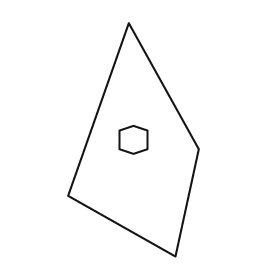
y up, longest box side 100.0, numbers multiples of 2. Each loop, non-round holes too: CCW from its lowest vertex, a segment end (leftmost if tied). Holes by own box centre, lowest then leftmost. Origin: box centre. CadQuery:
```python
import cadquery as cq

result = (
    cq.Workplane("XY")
    .moveTo(18.0, -50.0)
    .lineTo(28.0, -4.0)
    .lineTo(-2.0, 50.0)
    .lineTo(-28.0, -24.0)
    .close()
    .moveTo(0.0, -6.0)
    .lineTo(6.0, -4.0)
    .lineTo(6.0, 4.0)
    .lineTo(0.0, 6.0)
    .lineTo(-6.0, 4.0)
    .lineTo(-6.0, -4.0)
    .close()
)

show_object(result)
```